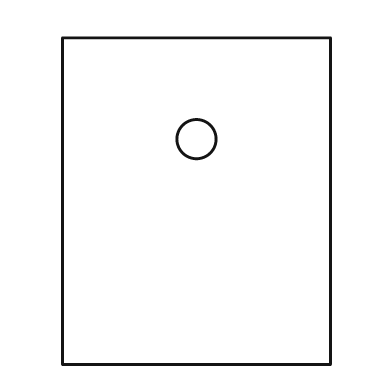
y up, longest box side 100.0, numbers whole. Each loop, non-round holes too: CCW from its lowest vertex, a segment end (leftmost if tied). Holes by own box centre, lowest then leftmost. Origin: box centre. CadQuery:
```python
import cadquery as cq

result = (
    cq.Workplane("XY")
    .moveTo(-41.0, -50.0)
    .lineTo(41.0, -50.0)
    .lineTo(41.0, 50.0)
    .lineTo(-41.0, 50.0)
    .close()
    .moveTo(0.0, 19.0)
    .circle(6.0)
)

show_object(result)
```